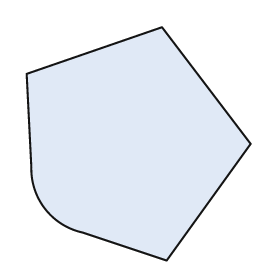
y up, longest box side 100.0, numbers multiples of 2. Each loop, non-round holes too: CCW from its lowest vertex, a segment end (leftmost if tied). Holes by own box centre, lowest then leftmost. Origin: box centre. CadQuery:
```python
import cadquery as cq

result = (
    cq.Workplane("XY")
    .moveTo(12.0, -50.0)
    .lineTo(48.0, 0.0)
    .lineTo(10.0, 50.0)
    .lineTo(-48.0, 30.0)
    .lineTo(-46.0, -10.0)
    .threePointArc((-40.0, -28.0), (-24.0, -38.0))
    .close()
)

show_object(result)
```